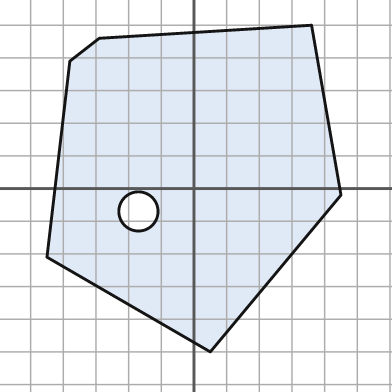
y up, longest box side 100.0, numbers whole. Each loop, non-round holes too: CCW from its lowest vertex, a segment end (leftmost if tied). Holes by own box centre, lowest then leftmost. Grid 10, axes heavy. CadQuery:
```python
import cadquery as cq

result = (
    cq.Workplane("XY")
    .moveTo(5.0, -50.0)
    .lineTo(45.0, -2.0)
    .lineTo(36.0, 50.0)
    .lineTo(-29.0, 46.0)
    .lineTo(-38.0, 39.0)
    .lineTo(-45.0, -21.0)
    .close()
    .moveTo(-17.0, -7.0)
    .circle(6.0)
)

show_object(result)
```